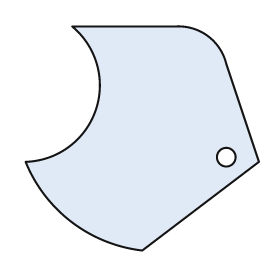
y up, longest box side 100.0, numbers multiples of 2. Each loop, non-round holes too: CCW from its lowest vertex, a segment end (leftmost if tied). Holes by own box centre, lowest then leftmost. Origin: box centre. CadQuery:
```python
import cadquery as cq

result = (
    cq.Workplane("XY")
    .moveTo(0.0, -48.0)
    .lineTo(50.0, -10.0)
    .lineTo(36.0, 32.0)
    .threePointArc((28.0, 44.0), (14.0, 48.0))
    .lineTo(-30.0, 48.0)
    .threePointArc((-20.0, 12.0), (-50.0, -10.0))
    .threePointArc((-30.0, -36.0), (0.0, -48.0))
    .close()
    .moveTo(36.0, -8.0)
    .circle(4.0)
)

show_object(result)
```